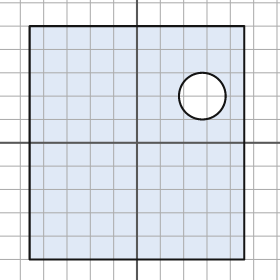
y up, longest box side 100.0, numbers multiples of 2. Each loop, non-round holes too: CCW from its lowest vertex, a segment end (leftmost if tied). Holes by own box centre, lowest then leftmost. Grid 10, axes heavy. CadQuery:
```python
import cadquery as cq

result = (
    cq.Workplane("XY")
    .moveTo(-46.0, -50.0)
    .lineTo(46.0, -50.0)
    .lineTo(46.0, 50.0)
    .lineTo(-46.0, 50.0)
    .close()
    .moveTo(28.0, 20.0)
    .circle(10.0)
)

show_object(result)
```